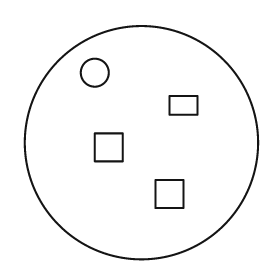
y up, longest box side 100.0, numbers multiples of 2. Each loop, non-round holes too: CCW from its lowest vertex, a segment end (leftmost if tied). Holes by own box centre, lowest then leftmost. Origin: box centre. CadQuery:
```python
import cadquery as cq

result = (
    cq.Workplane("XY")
    .moveTo(0.0, 0.0)
    .circle(50.0)
    .moveTo(6.0, -28.0)
    .lineTo(18.0, -28.0)
    .lineTo(18.0, -16.0)
    .lineTo(6.0, -16.0)
    .close()
    .moveTo(-20.0, -8.0)
    .lineTo(-8.0, -8.0)
    .lineTo(-8.0, 4.0)
    .lineTo(-20.0, 4.0)
    .close()
    .moveTo(12.0, 12.0)
    .lineTo(24.0, 12.0)
    .lineTo(24.0, 20.0)
    .lineTo(12.0, 20.0)
    .close()
    .moveTo(-20.0, 30.0)
    .circle(6.0)
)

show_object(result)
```